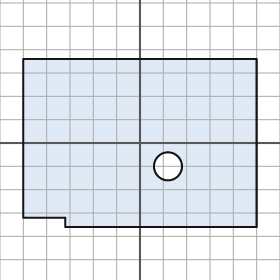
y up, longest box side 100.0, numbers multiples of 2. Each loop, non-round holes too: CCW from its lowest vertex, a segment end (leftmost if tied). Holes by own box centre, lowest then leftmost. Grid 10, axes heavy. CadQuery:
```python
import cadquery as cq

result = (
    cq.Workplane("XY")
    .moveTo(-32.0, -36.0)
    .lineTo(50.0, -36.0)
    .lineTo(50.0, 36.0)
    .lineTo(-50.0, 36.0)
    .lineTo(-50.0, -32.0)
    .lineTo(-32.0, -32.0)
    .close()
    .moveTo(12.0, -10.0)
    .circle(6.0)
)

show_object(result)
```